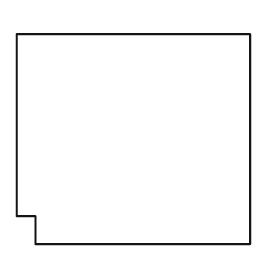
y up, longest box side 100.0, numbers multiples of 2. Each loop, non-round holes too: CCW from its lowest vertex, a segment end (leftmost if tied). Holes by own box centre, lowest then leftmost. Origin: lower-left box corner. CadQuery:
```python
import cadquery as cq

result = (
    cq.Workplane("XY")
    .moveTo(8.0, 0.0)
    .lineTo(100.0, 0.0)
    .lineTo(100.0, 90.0)
    .lineTo(0.0, 90.0)
    .lineTo(0.0, 12.0)
    .lineTo(8.0, 12.0)
    .close()
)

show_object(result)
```